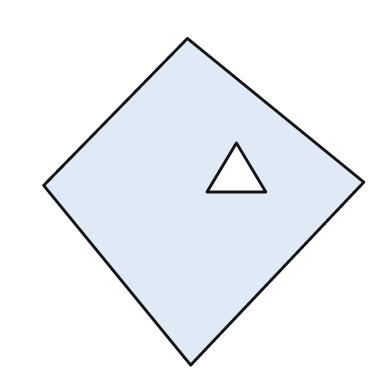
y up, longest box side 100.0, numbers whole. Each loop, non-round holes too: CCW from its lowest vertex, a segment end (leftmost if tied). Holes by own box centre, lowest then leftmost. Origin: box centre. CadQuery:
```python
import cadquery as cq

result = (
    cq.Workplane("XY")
    .moveTo(-4.0, -50.0)
    .lineTo(49.0, 6.0)
    .lineTo(-5.0, 50.0)
    .lineTo(-49.0, 5.0)
    .close()
    .moveTo(1.0, 3.0)
    .lineTo(19.0, 3.0)
    .lineTo(10.0, 18.0)
    .close()
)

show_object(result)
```